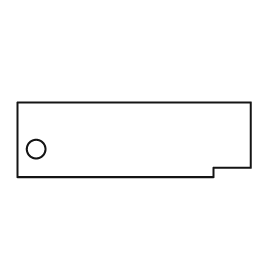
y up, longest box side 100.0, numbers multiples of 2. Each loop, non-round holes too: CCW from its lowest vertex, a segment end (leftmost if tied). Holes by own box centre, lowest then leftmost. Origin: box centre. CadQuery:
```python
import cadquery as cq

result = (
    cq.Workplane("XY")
    .moveTo(-50.0, -16.0)
    .lineTo(34.0, -16.0)
    .lineTo(34.0, -12.0)
    .lineTo(50.0, -12.0)
    .lineTo(50.0, 16.0)
    .lineTo(-50.0, 16.0)
    .close()
    .moveTo(-42.0, -4.0)
    .circle(4.0)
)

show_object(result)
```